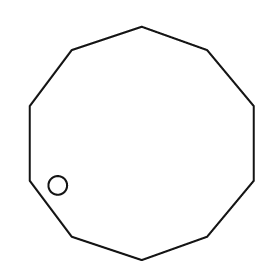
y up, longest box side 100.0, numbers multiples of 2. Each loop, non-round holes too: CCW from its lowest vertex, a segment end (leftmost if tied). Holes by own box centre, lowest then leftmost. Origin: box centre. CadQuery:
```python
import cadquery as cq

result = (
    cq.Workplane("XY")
    .moveTo(0.0, -50.0)
    .lineTo(28.0, -40.0)
    .lineTo(48.0, -16.0)
    .lineTo(48.0, 16.0)
    .lineTo(28.0, 40.0)
    .lineTo(0.0, 50.0)
    .lineTo(-30.0, 40.0)
    .lineTo(-48.0, 16.0)
    .lineTo(-48.0, -16.0)
    .lineTo(-30.0, -40.0)
    .close()
    .moveTo(-36.0, -18.0)
    .circle(4.0)
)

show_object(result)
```